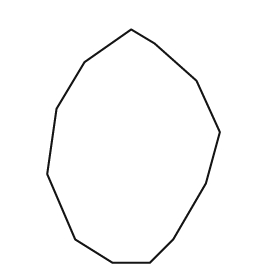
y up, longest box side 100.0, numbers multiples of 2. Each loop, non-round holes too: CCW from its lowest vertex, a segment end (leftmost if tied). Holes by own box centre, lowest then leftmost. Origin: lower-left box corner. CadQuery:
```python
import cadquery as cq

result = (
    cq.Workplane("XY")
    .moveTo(28.0, 0.0)
    .lineTo(44.0, 0.0)
    .lineTo(54.0, 10.0)
    .lineTo(68.0, 34.0)
    .lineTo(74.0, 56.0)
    .lineTo(64.0, 78.0)
    .lineTo(46.0, 94.0)
    .lineTo(36.0, 100.0)
    .lineTo(16.0, 86.0)
    .lineTo(4.0, 66.0)
    .lineTo(0.0, 38.0)
    .lineTo(12.0, 10.0)
    .close()
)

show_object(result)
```